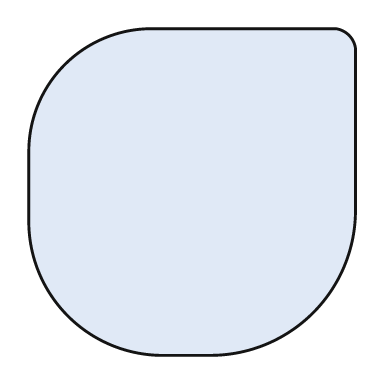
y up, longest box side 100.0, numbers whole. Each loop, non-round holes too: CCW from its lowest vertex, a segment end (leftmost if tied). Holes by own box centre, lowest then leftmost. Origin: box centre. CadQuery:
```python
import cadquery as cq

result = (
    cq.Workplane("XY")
    .moveTo(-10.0, -50.0)
    .lineTo(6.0, -50.0)
    .threePointArc((37.0, -37.0), (50.0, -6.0))
    .lineTo(50.0, 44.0)
    .threePointArc((48.0, 48.0), (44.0, 50.0))
    .lineTo(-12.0, 50.0)
    .threePointArc((-39.0, 39.0), (-50.0, 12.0))
    .lineTo(-50.0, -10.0)
    .threePointArc((-38.0, -38.0), (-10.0, -50.0))
    .close()
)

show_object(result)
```